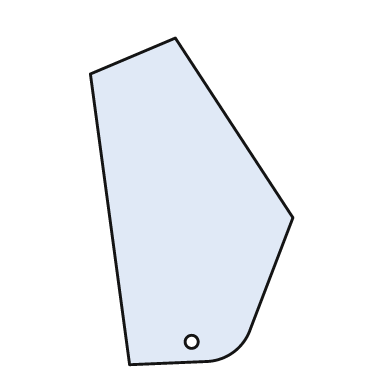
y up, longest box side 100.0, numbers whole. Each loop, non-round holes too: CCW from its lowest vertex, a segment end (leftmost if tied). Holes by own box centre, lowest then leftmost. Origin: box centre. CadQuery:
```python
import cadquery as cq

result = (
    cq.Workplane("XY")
    .moveTo(-19.0, -50.0)
    .lineTo(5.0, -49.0)
    .threePointArc((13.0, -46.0), (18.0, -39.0))
    .lineTo(31.0, -5.0)
    .lineTo(-5.0, 50.0)
    .lineTo(-31.0, 39.0)
    .close()
    .moveTo(0.0, -43.0)
    .circle(2.0)
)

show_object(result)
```